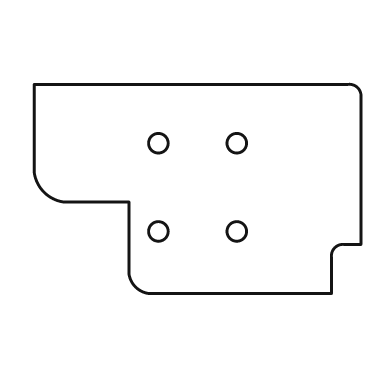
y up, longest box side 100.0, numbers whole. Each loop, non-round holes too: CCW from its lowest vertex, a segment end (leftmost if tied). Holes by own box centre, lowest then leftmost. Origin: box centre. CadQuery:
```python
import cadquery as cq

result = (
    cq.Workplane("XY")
    .moveTo(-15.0, -32.0)
    .lineTo(41.0, -32.0)
    .lineTo(41.0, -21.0)
    .threePointArc((42.0, -18.0), (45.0, -17.0))
    .lineTo(50.0, -17.0)
    .lineTo(50.0, 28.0)
    .threePointArc((49.0, 31.0), (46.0, 32.0))
    .lineTo(-50.0, 32.0)
    .lineTo(-50.0, 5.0)
    .threePointArc((-47.0, -1.0), (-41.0, -4.0))
    .lineTo(-21.0, -4.0)
    .lineTo(-21.0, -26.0)
    .threePointArc((-19.0, -30.0), (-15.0, -32.0))
    .close()
    .moveTo(-12.0, -13.0)
    .circle(3.0)
    .moveTo(12.0, -13.0)
    .circle(3.0)
    .moveTo(-12.0, 14.0)
    .circle(3.0)
    .moveTo(12.0, 14.0)
    .circle(3.0)
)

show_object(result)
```